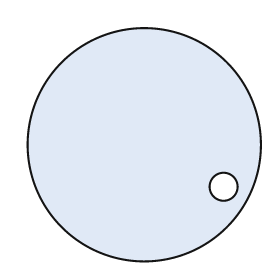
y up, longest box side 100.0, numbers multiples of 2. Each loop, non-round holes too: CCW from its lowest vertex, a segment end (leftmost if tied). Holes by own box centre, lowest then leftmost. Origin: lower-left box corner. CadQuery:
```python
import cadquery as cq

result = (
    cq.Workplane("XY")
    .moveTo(50.0, 50.0)
    .circle(50.0)
    .moveTo(84.0, 32.0)
    .circle(6.0)
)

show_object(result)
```